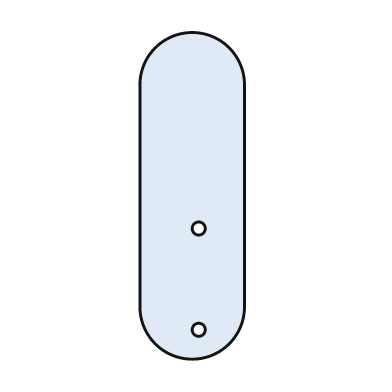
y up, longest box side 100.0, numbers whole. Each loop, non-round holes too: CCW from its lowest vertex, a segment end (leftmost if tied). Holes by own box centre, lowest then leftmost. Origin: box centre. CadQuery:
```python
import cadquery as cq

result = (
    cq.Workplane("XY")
    .moveTo(-16.0, -34.0)
    .threePointArc((0.0, -50.0), (16.0, -34.0))
    .lineTo(16.0, 34.0)
    .threePointArc((0.0, 50.0), (-16.0, 34.0))
    .close()
    .moveTo(2.0, -41.0)
    .circle(2.0)
    .moveTo(2.0, -10.0)
    .circle(2.0)
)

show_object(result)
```